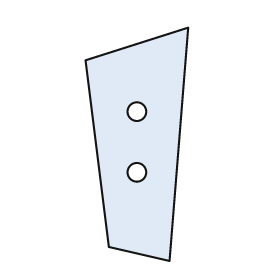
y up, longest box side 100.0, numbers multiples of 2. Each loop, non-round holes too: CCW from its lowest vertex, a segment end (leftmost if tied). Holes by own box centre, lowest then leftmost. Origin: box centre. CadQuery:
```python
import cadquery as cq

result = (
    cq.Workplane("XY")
    .moveTo(14.0, -50.0)
    .lineTo(22.0, 50.0)
    .lineTo(-22.0, 36.0)
    .lineTo(-12.0, -44.0)
    .close()
    .moveTo(0.0, -12.0)
    .circle(4.0)
    .moveTo(0.0, 14.0)
    .circle(4.0)
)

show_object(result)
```